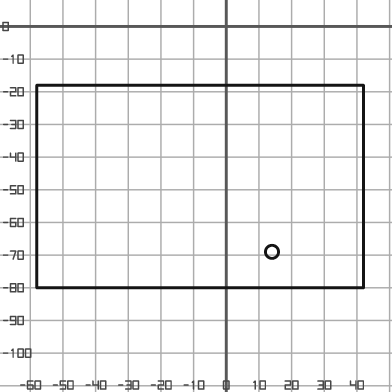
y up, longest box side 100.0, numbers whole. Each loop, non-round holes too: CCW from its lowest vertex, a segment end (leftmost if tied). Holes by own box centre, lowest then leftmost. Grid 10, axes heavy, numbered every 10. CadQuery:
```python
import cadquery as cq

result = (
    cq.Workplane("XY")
    .moveTo(-58.0, -80.0)
    .lineTo(42.0, -80.0)
    .lineTo(42.0, -18.0)
    .lineTo(-58.0, -18.0)
    .close()
    .moveTo(14.0, -69.0)
    .circle(2.0)
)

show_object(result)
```